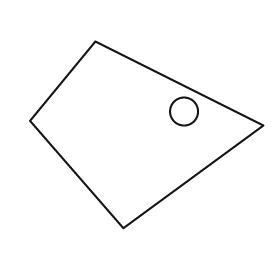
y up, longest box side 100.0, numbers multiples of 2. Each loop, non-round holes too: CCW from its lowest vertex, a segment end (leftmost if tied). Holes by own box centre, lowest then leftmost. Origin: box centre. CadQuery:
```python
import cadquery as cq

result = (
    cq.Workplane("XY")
    .moveTo(-10.0, -40.0)
    .lineTo(50.0, 4.0)
    .lineTo(-22.0, 40.0)
    .lineTo(-50.0, 6.0)
    .close()
    .moveTo(16.0, 10.0)
    .circle(6.0)
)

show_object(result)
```